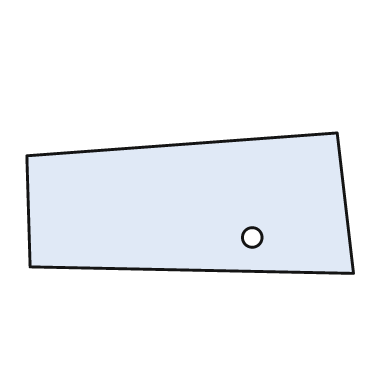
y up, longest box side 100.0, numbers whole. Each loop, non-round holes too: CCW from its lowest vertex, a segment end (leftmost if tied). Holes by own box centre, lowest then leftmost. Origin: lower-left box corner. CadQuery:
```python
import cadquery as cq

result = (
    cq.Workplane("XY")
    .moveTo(100.0, 0.0)
    .lineTo(95.0, 43.0)
    .lineTo(0.0, 36.0)
    .lineTo(1.0, 2.0)
    .close()
    .moveTo(69.0, 11.0)
    .circle(3.0)
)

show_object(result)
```